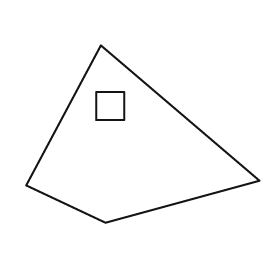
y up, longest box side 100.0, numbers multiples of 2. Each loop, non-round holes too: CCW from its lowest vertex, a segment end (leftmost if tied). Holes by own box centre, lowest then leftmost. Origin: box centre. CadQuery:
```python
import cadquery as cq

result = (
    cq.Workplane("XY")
    .moveTo(-16.0, -38.0)
    .lineTo(50.0, -20.0)
    .lineTo(-18.0, 38.0)
    .lineTo(-50.0, -22.0)
    .close()
    .moveTo(-20.0, 6.0)
    .lineTo(-8.0, 6.0)
    .lineTo(-8.0, 18.0)
    .lineTo(-20.0, 18.0)
    .close()
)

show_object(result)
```